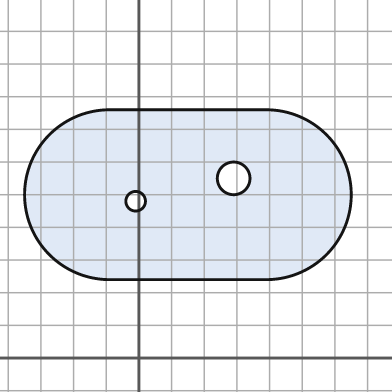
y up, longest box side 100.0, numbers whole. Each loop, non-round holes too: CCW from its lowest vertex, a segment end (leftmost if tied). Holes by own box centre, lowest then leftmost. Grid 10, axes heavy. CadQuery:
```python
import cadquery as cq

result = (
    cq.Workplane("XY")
    .moveTo(-9.0, 24.0)
    .lineTo(39.0, 24.0)
    .threePointArc((65.0, 50.0), (39.0, 76.0))
    .lineTo(-9.0, 76.0)
    .threePointArc((-35.0, 50.0), (-9.0, 24.0))
    .close()
    .moveTo(-1.0, 48.0)
    .circle(3.0)
    .moveTo(29.0, 55.0)
    .circle(5.0)
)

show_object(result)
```